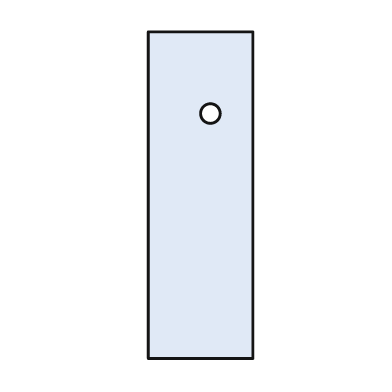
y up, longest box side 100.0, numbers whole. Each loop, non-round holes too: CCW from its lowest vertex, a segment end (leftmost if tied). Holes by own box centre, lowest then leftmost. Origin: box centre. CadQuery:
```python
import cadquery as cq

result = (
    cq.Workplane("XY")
    .moveTo(-16.0, -50.0)
    .lineTo(16.0, -50.0)
    .lineTo(16.0, 50.0)
    .lineTo(-16.0, 50.0)
    .close()
    .moveTo(3.0, 25.0)
    .circle(3.0)
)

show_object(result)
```